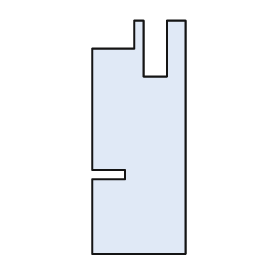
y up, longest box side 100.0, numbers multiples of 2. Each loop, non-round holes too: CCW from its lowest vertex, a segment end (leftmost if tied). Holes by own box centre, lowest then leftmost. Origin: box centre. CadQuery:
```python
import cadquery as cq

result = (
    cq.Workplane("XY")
    .moveTo(-20.0, -50.0)
    .lineTo(20.0, -50.0)
    .lineTo(20.0, 50.0)
    .lineTo(12.0, 50.0)
    .lineTo(12.0, 26.0)
    .lineTo(2.0, 26.0)
    .lineTo(2.0, 50.0)
    .lineTo(-2.0, 50.0)
    .lineTo(-2.0, 38.0)
    .lineTo(-20.0, 38.0)
    .lineTo(-20.0, -14.0)
    .lineTo(-6.0, -14.0)
    .lineTo(-6.0, -18.0)
    .lineTo(-20.0, -18.0)
    .close()
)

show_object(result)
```